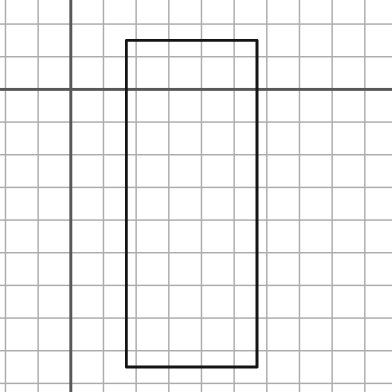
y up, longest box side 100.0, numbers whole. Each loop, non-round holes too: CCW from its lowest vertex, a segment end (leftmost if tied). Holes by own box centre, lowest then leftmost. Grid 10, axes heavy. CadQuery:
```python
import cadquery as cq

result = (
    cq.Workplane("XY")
    .moveTo(17.0, -85.0)
    .lineTo(57.0, -85.0)
    .lineTo(57.0, 15.0)
    .lineTo(17.0, 15.0)
    .close()
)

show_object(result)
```